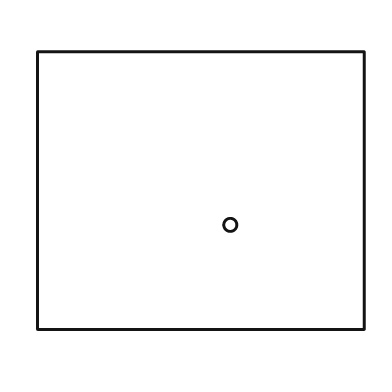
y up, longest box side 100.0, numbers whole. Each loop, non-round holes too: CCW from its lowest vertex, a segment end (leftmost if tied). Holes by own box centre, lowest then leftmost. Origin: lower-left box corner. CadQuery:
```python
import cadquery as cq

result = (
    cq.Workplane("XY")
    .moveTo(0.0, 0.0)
    .lineTo(100.0, 0.0)
    .lineTo(100.0, 85.0)
    .lineTo(0.0, 85.0)
    .close()
    .moveTo(59.0, 32.0)
    .circle(2.0)
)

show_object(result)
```